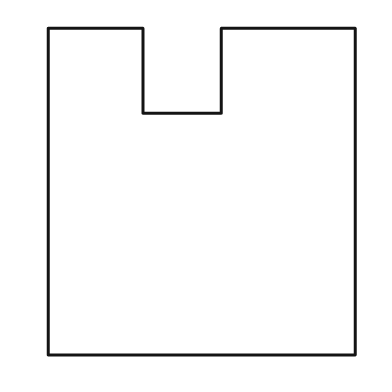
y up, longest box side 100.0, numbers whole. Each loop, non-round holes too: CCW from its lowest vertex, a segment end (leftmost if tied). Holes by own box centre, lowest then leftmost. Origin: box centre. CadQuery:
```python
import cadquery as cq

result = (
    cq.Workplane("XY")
    .moveTo(-47.0, -50.0)
    .lineTo(47.0, -50.0)
    .lineTo(47.0, 50.0)
    .lineTo(6.0, 50.0)
    .lineTo(6.0, 24.0)
    .lineTo(-18.0, 24.0)
    .lineTo(-18.0, 50.0)
    .lineTo(-47.0, 50.0)
    .close()
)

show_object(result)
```